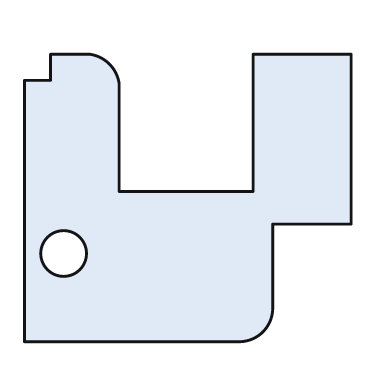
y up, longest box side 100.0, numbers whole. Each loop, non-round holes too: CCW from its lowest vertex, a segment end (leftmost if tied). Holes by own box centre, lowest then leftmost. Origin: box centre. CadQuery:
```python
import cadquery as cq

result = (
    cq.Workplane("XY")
    .moveTo(-50.0, -44.0)
    .lineTo(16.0, -44.0)
    .threePointArc((23.0, -41.0), (26.0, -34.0))
    .lineTo(26.0, -8.0)
    .lineTo(50.0, -8.0)
    .lineTo(50.0, 44.0)
    .lineTo(20.0, 44.0)
    .lineTo(20.0, 2.0)
    .lineTo(-21.0, 2.0)
    .lineTo(-21.0, 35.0)
    .threePointArc((-24.0, 41.0), (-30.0, 44.0))
    .lineTo(-42.0, 44.0)
    .lineTo(-42.0, 36.0)
    .lineTo(-50.0, 36.0)
    .close()
    .moveTo(-38.0, -17.0)
    .circle(7.0)
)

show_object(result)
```